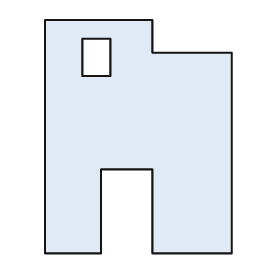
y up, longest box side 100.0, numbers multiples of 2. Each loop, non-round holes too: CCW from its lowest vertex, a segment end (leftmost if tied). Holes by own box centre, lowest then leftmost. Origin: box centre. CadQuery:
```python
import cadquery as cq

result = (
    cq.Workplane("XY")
    .moveTo(-40.0, -50.0)
    .lineTo(-16.0, -50.0)
    .lineTo(-16.0, -14.0)
    .lineTo(6.0, -14.0)
    .lineTo(6.0, -50.0)
    .lineTo(40.0, -50.0)
    .lineTo(40.0, 36.0)
    .lineTo(6.0, 36.0)
    .lineTo(6.0, 50.0)
    .lineTo(-40.0, 50.0)
    .close()
    .moveTo(-24.0, 26.0)
    .lineTo(-12.0, 26.0)
    .lineTo(-12.0, 42.0)
    .lineTo(-24.0, 42.0)
    .close()
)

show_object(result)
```